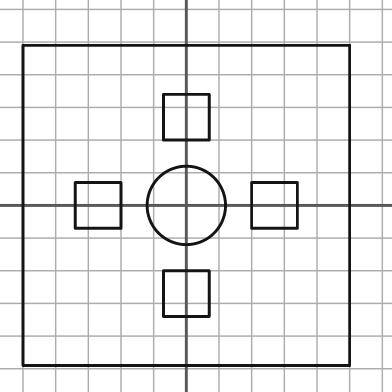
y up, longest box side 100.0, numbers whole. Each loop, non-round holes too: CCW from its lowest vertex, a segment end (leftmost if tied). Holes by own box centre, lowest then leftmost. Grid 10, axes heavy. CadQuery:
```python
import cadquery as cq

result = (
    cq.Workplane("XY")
    .moveTo(-50.0, -49.0)
    .lineTo(50.0, -49.0)
    .lineTo(50.0, 49.0)
    .lineTo(-50.0, 49.0)
    .close()
    .moveTo(-7.0, -34.0)
    .lineTo(7.0, -34.0)
    .lineTo(7.0, -20.0)
    .lineTo(-7.0, -20.0)
    .close()
    .moveTo(-34.0, -7.0)
    .lineTo(-20.0, -7.0)
    .lineTo(-20.0, 7.0)
    .lineTo(-34.0, 7.0)
    .close()
    .moveTo(0.0, 0.0)
    .circle(12.0)
    .moveTo(20.0, -7.0)
    .lineTo(34.0, -7.0)
    .lineTo(34.0, 7.0)
    .lineTo(20.0, 7.0)
    .close()
    .moveTo(-7.0, 20.0)
    .lineTo(7.0, 20.0)
    .lineTo(7.0, 34.0)
    .lineTo(-7.0, 34.0)
    .close()
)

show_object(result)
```